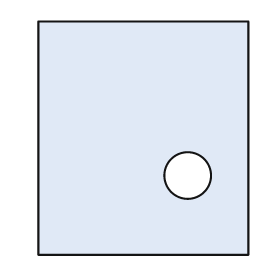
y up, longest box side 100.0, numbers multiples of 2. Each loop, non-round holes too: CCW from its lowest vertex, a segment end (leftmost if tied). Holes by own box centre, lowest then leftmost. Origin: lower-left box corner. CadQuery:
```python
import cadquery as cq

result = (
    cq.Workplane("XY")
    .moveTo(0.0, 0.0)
    .lineTo(90.0, 0.0)
    .lineTo(90.0, 100.0)
    .lineTo(0.0, 100.0)
    .close()
    .moveTo(64.0, 34.0)
    .circle(10.0)
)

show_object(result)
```